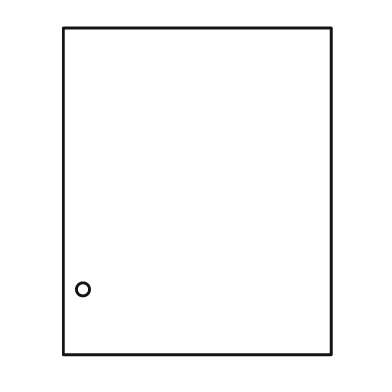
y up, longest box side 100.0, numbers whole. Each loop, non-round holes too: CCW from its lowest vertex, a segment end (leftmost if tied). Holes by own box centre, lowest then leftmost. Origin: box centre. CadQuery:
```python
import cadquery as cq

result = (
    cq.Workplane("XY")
    .moveTo(-41.0, -50.0)
    .lineTo(41.0, -50.0)
    .lineTo(41.0, 50.0)
    .lineTo(-41.0, 50.0)
    .close()
    .moveTo(-35.0, -30.0)
    .circle(2.0)
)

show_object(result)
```